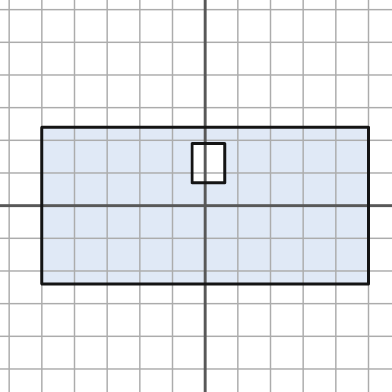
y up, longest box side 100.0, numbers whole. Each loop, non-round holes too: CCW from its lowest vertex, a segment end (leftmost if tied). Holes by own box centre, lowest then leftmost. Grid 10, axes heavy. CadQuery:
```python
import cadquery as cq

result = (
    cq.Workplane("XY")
    .moveTo(-50.0, -24.0)
    .lineTo(50.0, -24.0)
    .lineTo(50.0, 24.0)
    .lineTo(-50.0, 24.0)
    .close()
    .moveTo(-4.0, 7.0)
    .lineTo(6.0, 7.0)
    .lineTo(6.0, 19.0)
    .lineTo(-4.0, 19.0)
    .close()
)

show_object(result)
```